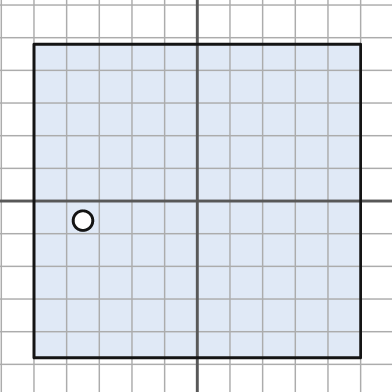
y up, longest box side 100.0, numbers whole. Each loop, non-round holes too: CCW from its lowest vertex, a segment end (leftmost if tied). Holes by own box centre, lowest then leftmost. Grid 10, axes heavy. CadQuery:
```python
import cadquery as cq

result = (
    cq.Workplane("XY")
    .moveTo(-50.0, -48.0)
    .lineTo(50.0, -48.0)
    .lineTo(50.0, 48.0)
    .lineTo(-50.0, 48.0)
    .close()
    .moveTo(-35.0, -6.0)
    .circle(3.0)
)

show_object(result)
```